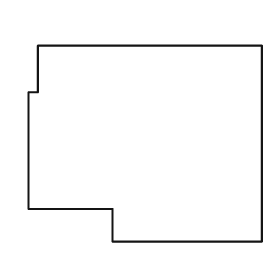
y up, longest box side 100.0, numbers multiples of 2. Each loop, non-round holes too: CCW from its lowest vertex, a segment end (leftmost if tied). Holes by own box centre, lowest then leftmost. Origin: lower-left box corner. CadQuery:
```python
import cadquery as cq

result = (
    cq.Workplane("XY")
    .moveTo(36.0, 0.0)
    .lineTo(100.0, 0.0)
    .lineTo(100.0, 84.0)
    .lineTo(4.0, 84.0)
    .lineTo(4.0, 64.0)
    .lineTo(0.0, 64.0)
    .lineTo(0.0, 14.0)
    .lineTo(36.0, 14.0)
    .close()
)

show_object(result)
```